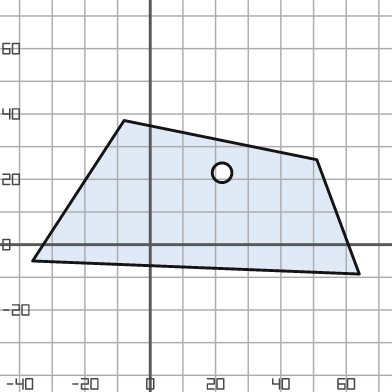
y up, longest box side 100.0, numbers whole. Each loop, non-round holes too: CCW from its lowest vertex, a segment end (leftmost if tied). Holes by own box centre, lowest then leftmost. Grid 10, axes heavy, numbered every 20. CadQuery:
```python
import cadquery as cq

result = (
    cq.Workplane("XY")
    .moveTo(64.0, -9.0)
    .lineTo(51.0, 26.0)
    .lineTo(-8.0, 38.0)
    .lineTo(-36.0, -5.0)
    .close()
    .moveTo(22.0, 22.0)
    .circle(3.0)
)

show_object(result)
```